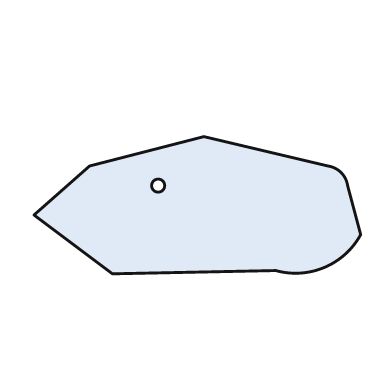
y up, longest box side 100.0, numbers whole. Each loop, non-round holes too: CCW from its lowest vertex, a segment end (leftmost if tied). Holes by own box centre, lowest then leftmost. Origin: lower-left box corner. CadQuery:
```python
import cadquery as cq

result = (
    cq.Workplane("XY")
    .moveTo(24.0, 0.0)
    .lineTo(74.0, 1.0)
    .threePointArc((89.0, 2.0), (100.0, 12.0))
    .lineTo(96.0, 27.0)
    .threePointArc((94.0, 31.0), (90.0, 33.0))
    .lineTo(52.0, 42.0)
    .lineTo(17.0, 33.0)
    .lineTo(0.0, 18.0)
    .close()
    .moveTo(38.0, 27.0)
    .circle(2.0)
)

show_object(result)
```